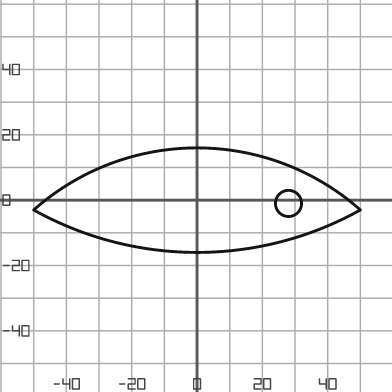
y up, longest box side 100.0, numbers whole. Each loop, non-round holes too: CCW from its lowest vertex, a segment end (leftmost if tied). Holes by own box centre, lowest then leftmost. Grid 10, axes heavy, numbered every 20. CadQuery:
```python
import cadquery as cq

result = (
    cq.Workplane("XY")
    .moveTo(-50.0, -3.0)
    .threePointArc((0.0, -16.0), (50.0, -3.0))
    .threePointArc((0.0, 16.0), (-50.0, -3.0))
    .close()
    .moveTo(28.0, -1.0)
    .circle(4.0)
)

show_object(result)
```